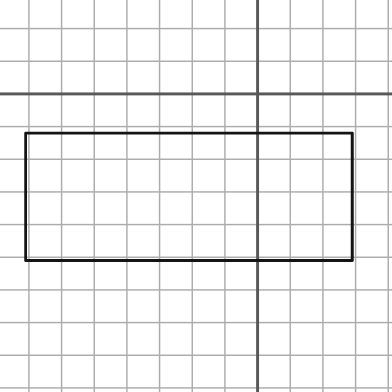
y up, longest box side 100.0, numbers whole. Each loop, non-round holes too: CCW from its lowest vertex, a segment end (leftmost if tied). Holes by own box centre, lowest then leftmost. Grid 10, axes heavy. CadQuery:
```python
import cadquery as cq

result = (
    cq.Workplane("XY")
    .moveTo(-71.0, -51.0)
    .lineTo(29.0, -51.0)
    .lineTo(29.0, -12.0)
    .lineTo(-71.0, -12.0)
    .close()
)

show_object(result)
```